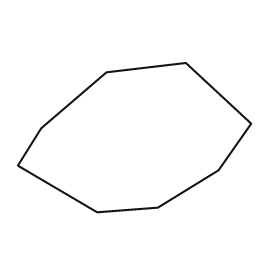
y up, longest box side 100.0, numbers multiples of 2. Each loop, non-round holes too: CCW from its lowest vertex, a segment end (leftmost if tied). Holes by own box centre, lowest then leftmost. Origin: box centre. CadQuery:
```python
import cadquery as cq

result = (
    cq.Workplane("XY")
    .moveTo(-16.0, -32.0)
    .lineTo(10.0, -30.0)
    .lineTo(36.0, -14.0)
    .lineTo(50.0, 6.0)
    .lineTo(22.0, 32.0)
    .lineTo(-12.0, 28.0)
    .lineTo(-40.0, 4.0)
    .lineTo(-50.0, -12.0)
    .close()
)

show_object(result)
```